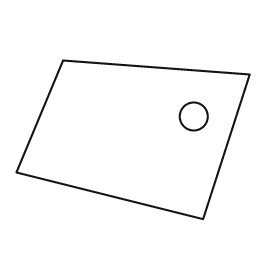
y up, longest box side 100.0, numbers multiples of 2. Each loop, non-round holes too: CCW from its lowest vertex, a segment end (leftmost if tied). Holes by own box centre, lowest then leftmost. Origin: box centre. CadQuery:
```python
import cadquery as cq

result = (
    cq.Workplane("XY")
    .moveTo(30.0, -34.0)
    .lineTo(50.0, 28.0)
    .lineTo(-30.0, 34.0)
    .lineTo(-50.0, -14.0)
    .close()
    .moveTo(26.0, 10.0)
    .circle(6.0)
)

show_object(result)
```